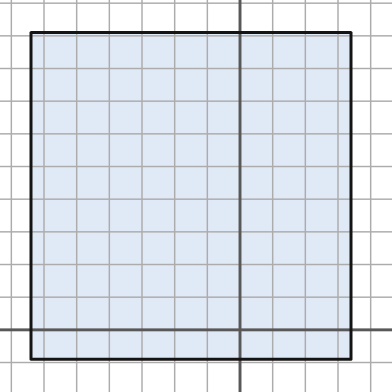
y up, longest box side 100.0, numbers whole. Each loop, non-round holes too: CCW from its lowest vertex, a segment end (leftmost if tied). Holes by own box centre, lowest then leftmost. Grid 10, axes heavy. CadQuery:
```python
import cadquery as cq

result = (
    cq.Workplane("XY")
    .moveTo(-64.0, -9.0)
    .lineTo(34.0, -9.0)
    .lineTo(34.0, 91.0)
    .lineTo(-64.0, 91.0)
    .close()
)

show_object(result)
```